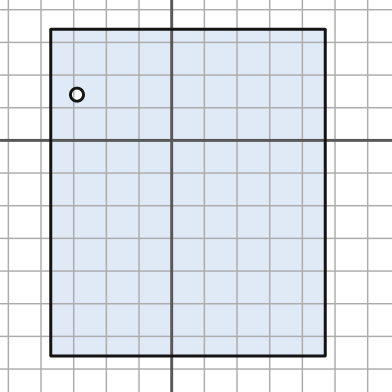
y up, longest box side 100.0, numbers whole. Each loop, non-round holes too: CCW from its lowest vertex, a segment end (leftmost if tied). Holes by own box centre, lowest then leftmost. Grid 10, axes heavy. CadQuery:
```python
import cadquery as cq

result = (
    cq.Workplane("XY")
    .moveTo(-37.0, -66.0)
    .lineTo(47.0, -66.0)
    .lineTo(47.0, 34.0)
    .lineTo(-37.0, 34.0)
    .close()
    .moveTo(-29.0, 14.0)
    .circle(2.0)
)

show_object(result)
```